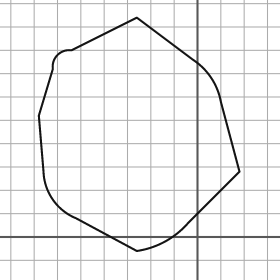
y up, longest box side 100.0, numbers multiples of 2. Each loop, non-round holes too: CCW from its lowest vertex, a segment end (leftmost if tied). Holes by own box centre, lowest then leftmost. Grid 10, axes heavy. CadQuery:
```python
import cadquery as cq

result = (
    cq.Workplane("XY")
    .moveTo(-26.0, -6.0)
    .threePointArc((-14.0, -2.0), (-4.0, 6.0))
    .lineTo(18.0, 28.0)
    .lineTo(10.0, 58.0)
    .threePointArc((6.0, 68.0), (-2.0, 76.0))
    .lineTo(-26.0, 94.0)
    .lineTo(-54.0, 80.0)
    .threePointArc((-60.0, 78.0), (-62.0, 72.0))
    .lineTo(-68.0, 52.0)
    .lineTo(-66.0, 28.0)
    .threePointArc((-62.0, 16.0), (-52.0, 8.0))
    .close()
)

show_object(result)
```